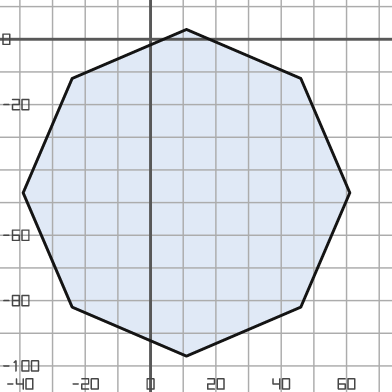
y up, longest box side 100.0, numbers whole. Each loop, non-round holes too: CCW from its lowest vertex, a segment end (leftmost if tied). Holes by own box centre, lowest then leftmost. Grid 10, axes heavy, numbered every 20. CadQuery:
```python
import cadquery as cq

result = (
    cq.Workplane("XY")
    .moveTo(11.0, -97.0)
    .lineTo(46.0, -82.0)
    .lineTo(61.0, -47.0)
    .lineTo(46.0, -12.0)
    .lineTo(11.0, 3.0)
    .lineTo(-24.0, -12.0)
    .lineTo(-39.0, -47.0)
    .lineTo(-24.0, -82.0)
    .close()
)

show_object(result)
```